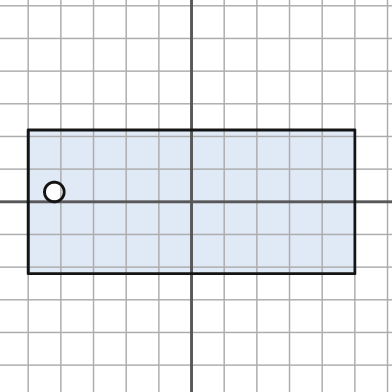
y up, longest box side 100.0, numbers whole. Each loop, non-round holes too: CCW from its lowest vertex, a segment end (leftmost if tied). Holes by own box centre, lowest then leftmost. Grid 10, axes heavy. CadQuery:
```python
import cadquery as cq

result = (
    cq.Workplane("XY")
    .moveTo(-50.0, -22.0)
    .lineTo(50.0, -22.0)
    .lineTo(50.0, 22.0)
    .lineTo(-50.0, 22.0)
    .close()
    .moveTo(-42.0, 3.0)
    .circle(3.0)
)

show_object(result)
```